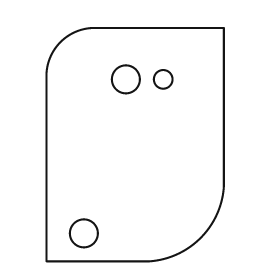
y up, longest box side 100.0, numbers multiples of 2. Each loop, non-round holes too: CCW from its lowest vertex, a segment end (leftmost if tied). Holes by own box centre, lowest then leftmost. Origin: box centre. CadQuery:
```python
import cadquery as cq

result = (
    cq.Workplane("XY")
    .moveTo(-38.0, -50.0)
    .lineTo(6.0, -50.0)
    .threePointArc((28.0, -40.0), (38.0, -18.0))
    .lineTo(38.0, 50.0)
    .lineTo(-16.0, 50.0)
    .threePointArc((-32.0, 44.0), (-38.0, 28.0))
    .close()
    .moveTo(-22.0, -38.0)
    .circle(6.0)
    .moveTo(-4.0, 28.0)
    .circle(6.0)
    .moveTo(12.0, 28.0)
    .circle(4.0)
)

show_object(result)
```